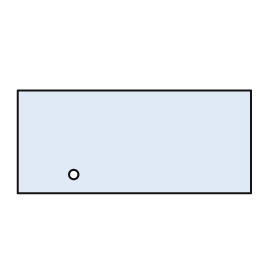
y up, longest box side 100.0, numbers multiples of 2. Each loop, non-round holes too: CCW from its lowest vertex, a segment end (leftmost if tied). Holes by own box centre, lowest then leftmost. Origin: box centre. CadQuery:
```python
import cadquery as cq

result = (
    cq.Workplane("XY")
    .moveTo(-50.0, -22.0)
    .lineTo(50.0, -22.0)
    .lineTo(50.0, 22.0)
    .lineTo(-50.0, 22.0)
    .close()
    .moveTo(-26.0, -14.0)
    .circle(2.0)
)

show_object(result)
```